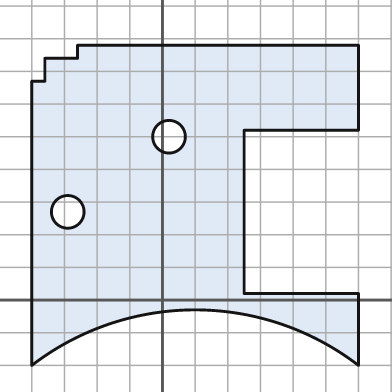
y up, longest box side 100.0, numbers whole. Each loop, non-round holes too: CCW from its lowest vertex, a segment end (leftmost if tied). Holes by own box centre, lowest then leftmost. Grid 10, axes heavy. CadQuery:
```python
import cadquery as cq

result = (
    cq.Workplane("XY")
    .moveTo(-40.0, -20.0)
    .threePointArc((10.0, -3.0), (60.0, -20.0))
    .lineTo(60.0, 2.0)
    .lineTo(25.0, 2.0)
    .lineTo(25.0, 52.0)
    .lineTo(60.0, 52.0)
    .lineTo(60.0, 78.0)
    .lineTo(-26.0, 78.0)
    .lineTo(-26.0, 74.0)
    .lineTo(-36.0, 74.0)
    .lineTo(-36.0, 67.0)
    .lineTo(-40.0, 67.0)
    .close()
    .moveTo(-29.0, 27.0)
    .circle(5.0)
    .moveTo(2.0, 50.0)
    .circle(5.0)
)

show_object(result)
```